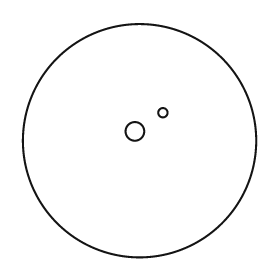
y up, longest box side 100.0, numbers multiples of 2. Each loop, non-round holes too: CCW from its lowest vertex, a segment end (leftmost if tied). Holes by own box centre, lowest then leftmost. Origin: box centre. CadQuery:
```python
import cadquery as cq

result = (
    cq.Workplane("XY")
    .moveTo(0.0, 0.0)
    .circle(50.0)
    .moveTo(-2.0, 4.0)
    .circle(4.0)
    .moveTo(10.0, 12.0)
    .circle(2.0)
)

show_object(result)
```